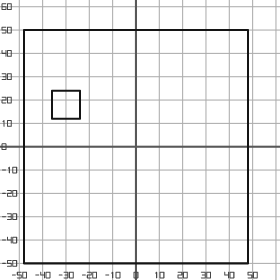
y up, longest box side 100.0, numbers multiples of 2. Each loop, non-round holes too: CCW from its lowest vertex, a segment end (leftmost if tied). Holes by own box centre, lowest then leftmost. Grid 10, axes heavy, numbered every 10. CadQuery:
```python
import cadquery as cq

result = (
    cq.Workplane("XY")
    .moveTo(-48.0, -50.0)
    .lineTo(48.0, -50.0)
    .lineTo(48.0, 50.0)
    .lineTo(-48.0, 50.0)
    .close()
    .moveTo(-36.0, 12.0)
    .lineTo(-24.0, 12.0)
    .lineTo(-24.0, 24.0)
    .lineTo(-36.0, 24.0)
    .close()
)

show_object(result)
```